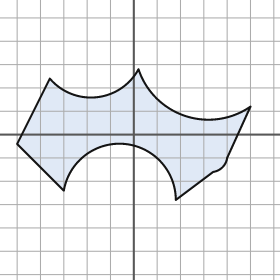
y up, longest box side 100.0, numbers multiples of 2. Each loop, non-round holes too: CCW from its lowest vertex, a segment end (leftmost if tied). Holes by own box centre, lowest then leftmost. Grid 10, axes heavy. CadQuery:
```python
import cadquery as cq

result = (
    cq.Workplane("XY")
    .moveTo(18.0, -28.0)
    .lineTo(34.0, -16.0)
    .threePointArc((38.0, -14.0), (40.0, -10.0))
    .lineTo(50.0, 12.0)
    .threePointArc((22.0, 8.0), (2.0, 28.0))
    .threePointArc((-16.0, 16.0), (-36.0, 24.0))
    .lineTo(-50.0, -4.0)
    .lineTo(-30.0, -24.0)
    .threePointArc((-4.0, -4.0), (18.0, -28.0))
    .close()
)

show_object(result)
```